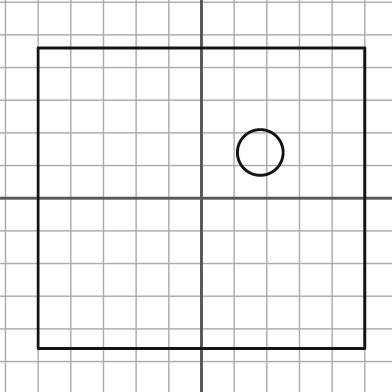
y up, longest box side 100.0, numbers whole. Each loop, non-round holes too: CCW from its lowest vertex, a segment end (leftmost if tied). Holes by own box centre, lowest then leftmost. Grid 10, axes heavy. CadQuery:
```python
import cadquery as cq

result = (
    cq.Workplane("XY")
    .moveTo(-50.0, -46.0)
    .lineTo(50.0, -46.0)
    .lineTo(50.0, 46.0)
    .lineTo(-50.0, 46.0)
    .close()
    .moveTo(18.0, 14.0)
    .circle(7.0)
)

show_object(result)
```